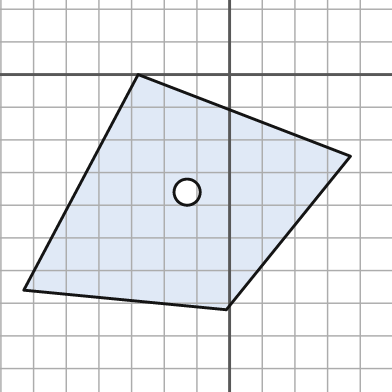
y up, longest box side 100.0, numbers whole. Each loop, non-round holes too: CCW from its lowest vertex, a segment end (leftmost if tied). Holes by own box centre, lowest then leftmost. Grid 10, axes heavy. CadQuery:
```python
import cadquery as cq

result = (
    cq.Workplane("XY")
    .moveTo(-1.0, -72.0)
    .lineTo(37.0, -25.0)
    .lineTo(-28.0, 0.0)
    .lineTo(-63.0, -66.0)
    .close()
    .moveTo(-13.0, -36.0)
    .circle(4.0)
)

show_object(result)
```